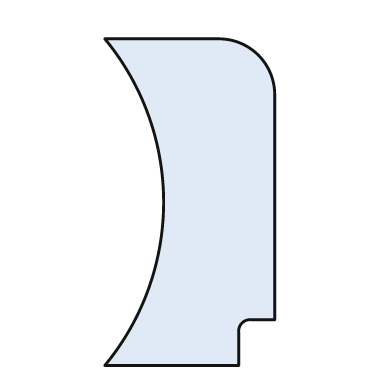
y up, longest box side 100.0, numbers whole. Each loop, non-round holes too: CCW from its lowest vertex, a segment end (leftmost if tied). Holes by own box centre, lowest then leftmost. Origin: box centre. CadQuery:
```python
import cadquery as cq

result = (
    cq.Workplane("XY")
    .moveTo(-26.0, -50.0)
    .lineTo(15.0, -50.0)
    .lineTo(15.0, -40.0)
    .threePointArc((16.0, -37.0), (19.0, -36.0))
    .lineTo(26.0, -36.0)
    .lineTo(26.0, 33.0)
    .threePointArc((21.0, 45.0), (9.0, 50.0))
    .lineTo(-26.0, 50.0)
    .threePointArc((-8.0, 0.0), (-26.0, -50.0))
    .close()
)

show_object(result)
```